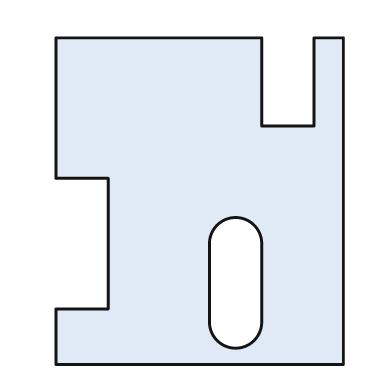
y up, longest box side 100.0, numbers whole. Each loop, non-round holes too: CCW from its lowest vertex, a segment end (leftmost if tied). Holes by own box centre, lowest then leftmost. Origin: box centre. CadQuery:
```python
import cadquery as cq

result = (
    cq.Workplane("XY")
    .moveTo(-44.0, -50.0)
    .lineTo(44.0, -50.0)
    .lineTo(44.0, 50.0)
    .lineTo(35.0, 50.0)
    .lineTo(35.0, 23.0)
    .lineTo(19.0, 23.0)
    .lineTo(19.0, 50.0)
    .lineTo(-44.0, 50.0)
    .lineTo(-44.0, 7.0)
    .lineTo(-28.0, 7.0)
    .lineTo(-28.0, -33.0)
    .lineTo(-44.0, -33.0)
    .close()
    .moveTo(3.0, -37.0)
    .threePointArc((11.0, -45.0), (19.0, -37.0))
    .lineTo(19.0, -13.0)
    .threePointArc((11.0, -5.0), (3.0, -13.0))
    .close()
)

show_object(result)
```